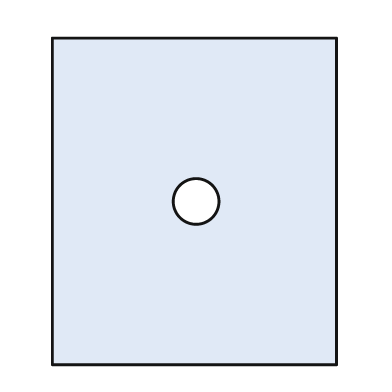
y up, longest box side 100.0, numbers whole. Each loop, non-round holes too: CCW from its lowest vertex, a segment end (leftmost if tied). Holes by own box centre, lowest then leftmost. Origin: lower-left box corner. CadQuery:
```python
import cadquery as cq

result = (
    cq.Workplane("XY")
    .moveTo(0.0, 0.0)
    .lineTo(87.0, 0.0)
    .lineTo(87.0, 100.0)
    .lineTo(0.0, 100.0)
    .close()
    .moveTo(44.0, 50.0)
    .circle(7.0)
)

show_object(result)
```